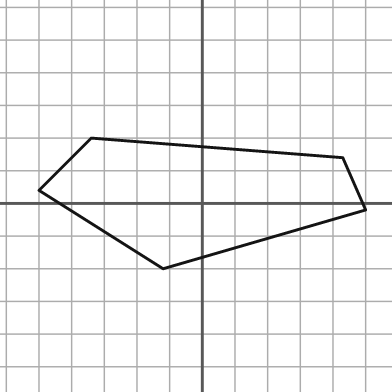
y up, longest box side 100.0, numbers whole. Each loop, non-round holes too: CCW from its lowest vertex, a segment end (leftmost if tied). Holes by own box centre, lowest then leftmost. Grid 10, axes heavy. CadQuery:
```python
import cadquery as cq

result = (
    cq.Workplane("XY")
    .moveTo(-12.0, -20.0)
    .lineTo(50.0, -2.0)
    .lineTo(43.0, 14.0)
    .lineTo(-34.0, 20.0)
    .lineTo(-50.0, 4.0)
    .close()
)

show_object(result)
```